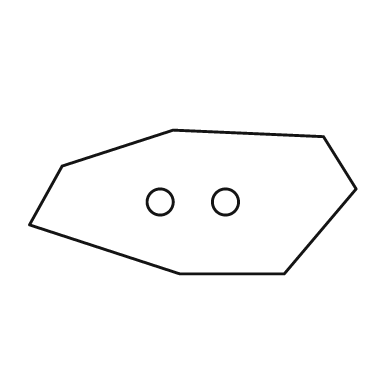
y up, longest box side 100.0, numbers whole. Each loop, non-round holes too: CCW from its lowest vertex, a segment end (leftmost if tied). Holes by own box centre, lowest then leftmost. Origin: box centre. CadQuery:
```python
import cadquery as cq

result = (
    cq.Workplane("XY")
    .moveTo(-4.0, -22.0)
    .lineTo(28.0, -22.0)
    .lineTo(50.0, 4.0)
    .lineTo(40.0, 20.0)
    .lineTo(-6.0, 22.0)
    .lineTo(-40.0, 11.0)
    .lineTo(-50.0, -7.0)
    .close()
    .moveTo(-10.0, 0.0)
    .circle(4.0)
    .moveTo(10.0, 0.0)
    .circle(4.0)
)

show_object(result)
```